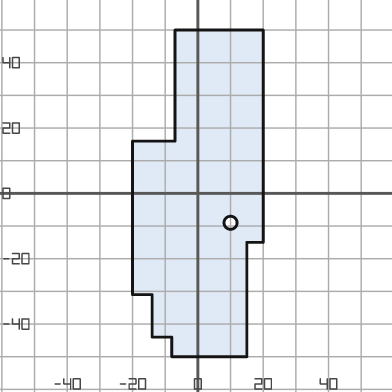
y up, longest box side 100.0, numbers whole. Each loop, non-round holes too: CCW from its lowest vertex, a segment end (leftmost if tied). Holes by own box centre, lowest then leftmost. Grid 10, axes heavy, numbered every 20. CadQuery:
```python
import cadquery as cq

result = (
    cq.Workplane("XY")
    .moveTo(-8.0, -50.0)
    .lineTo(15.0, -50.0)
    .lineTo(15.0, -15.0)
    .lineTo(20.0, -15.0)
    .lineTo(20.0, 50.0)
    .lineTo(-7.0, 50.0)
    .lineTo(-7.0, 16.0)
    .lineTo(-20.0, 16.0)
    .lineTo(-20.0, -31.0)
    .lineTo(-14.0, -31.0)
    .lineTo(-14.0, -44.0)
    .lineTo(-8.0, -44.0)
    .close()
    .moveTo(10.0, -9.0)
    .circle(2.0)
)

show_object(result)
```